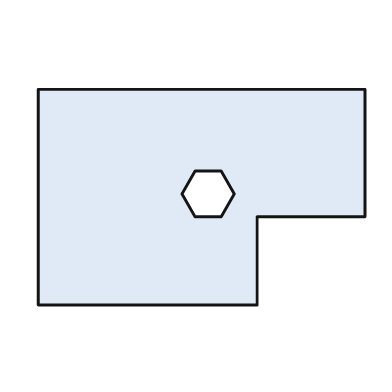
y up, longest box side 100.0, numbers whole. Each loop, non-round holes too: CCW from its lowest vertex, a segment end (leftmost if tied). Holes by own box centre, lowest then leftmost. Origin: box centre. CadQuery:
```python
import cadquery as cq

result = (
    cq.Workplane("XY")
    .moveTo(-50.0, -33.0)
    .lineTo(17.0, -33.0)
    .lineTo(17.0, -6.0)
    .lineTo(50.0, -6.0)
    .lineTo(50.0, 33.0)
    .lineTo(-50.0, 33.0)
    .close()
    .moveTo(-2.0, -6.0)
    .lineTo(6.0, -6.0)
    .lineTo(10.0, 1.0)
    .lineTo(6.0, 8.0)
    .lineTo(-2.0, 8.0)
    .lineTo(-6.0, 1.0)
    .close()
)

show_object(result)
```